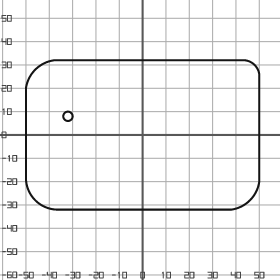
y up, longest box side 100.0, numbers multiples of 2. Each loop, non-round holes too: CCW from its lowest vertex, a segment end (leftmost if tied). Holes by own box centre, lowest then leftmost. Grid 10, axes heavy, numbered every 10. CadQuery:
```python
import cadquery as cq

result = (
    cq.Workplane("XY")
    .moveTo(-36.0, -32.0)
    .lineTo(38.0, -32.0)
    .threePointArc((46.0, -28.0), (50.0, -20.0))
    .lineTo(50.0, 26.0)
    .threePointArc((48.0, 30.0), (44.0, 32.0))
    .lineTo(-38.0, 32.0)
    .threePointArc((-46.0, 28.0), (-50.0, 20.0))
    .lineTo(-50.0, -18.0)
    .threePointArc((-46.0, -28.0), (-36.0, -32.0))
    .close()
    .moveTo(-32.0, 8.0)
    .circle(2.0)
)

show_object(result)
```